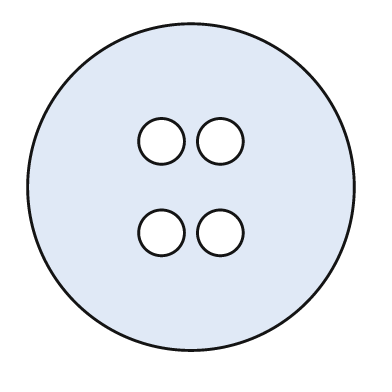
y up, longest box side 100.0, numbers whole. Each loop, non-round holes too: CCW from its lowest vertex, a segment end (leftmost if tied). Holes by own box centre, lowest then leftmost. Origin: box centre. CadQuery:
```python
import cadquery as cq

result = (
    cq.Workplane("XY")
    .moveTo(0.0, 0.0)
    .circle(50.0)
    .moveTo(-9.0, -14.0)
    .circle(7.0)
    .moveTo(9.0, -14.0)
    .circle(7.0)
    .moveTo(-9.0, 14.0)
    .circle(7.0)
    .moveTo(9.0, 14.0)
    .circle(7.0)
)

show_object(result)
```